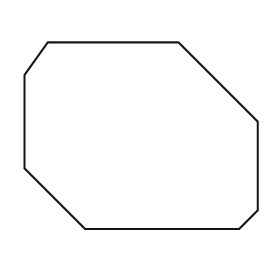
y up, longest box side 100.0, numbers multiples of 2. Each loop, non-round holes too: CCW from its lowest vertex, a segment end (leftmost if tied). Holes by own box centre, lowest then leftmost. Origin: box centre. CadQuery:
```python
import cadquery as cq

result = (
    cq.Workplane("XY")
    .moveTo(-24.0, -40.0)
    .lineTo(42.0, -40.0)
    .lineTo(50.0, -32.0)
    .lineTo(50.0, 6.0)
    .lineTo(16.0, 40.0)
    .lineTo(-40.0, 40.0)
    .lineTo(-50.0, 26.0)
    .lineTo(-50.0, -14.0)
    .close()
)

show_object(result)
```